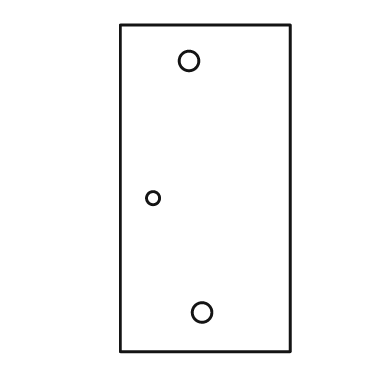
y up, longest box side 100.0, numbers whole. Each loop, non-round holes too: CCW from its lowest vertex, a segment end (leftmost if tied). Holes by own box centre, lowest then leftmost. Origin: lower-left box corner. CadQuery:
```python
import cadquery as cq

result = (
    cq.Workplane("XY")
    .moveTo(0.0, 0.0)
    .lineTo(52.0, 0.0)
    .lineTo(52.0, 100.0)
    .lineTo(0.0, 100.0)
    .close()
    .moveTo(25.0, 12.0)
    .circle(3.0)
    .moveTo(10.0, 47.0)
    .circle(2.0)
    .moveTo(21.0, 89.0)
    .circle(3.0)
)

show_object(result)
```